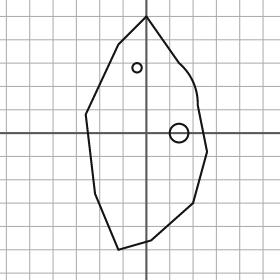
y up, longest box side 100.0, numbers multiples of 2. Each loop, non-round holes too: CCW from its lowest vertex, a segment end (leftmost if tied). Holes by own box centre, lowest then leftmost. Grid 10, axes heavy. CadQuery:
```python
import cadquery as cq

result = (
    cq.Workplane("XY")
    .moveTo(-12.0, -50.0)
    .lineTo(2.0, -46.0)
    .lineTo(20.0, -30.0)
    .lineTo(26.0, -8.0)
    .lineTo(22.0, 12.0)
    .threePointArc((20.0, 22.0), (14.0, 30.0))
    .lineTo(0.0, 50.0)
    .lineTo(-12.0, 38.0)
    .lineTo(-26.0, 8.0)
    .lineTo(-22.0, -26.0)
    .close()
    .moveTo(14.0, 0.0)
    .circle(4.0)
    .moveTo(-4.0, 28.0)
    .circle(2.0)
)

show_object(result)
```